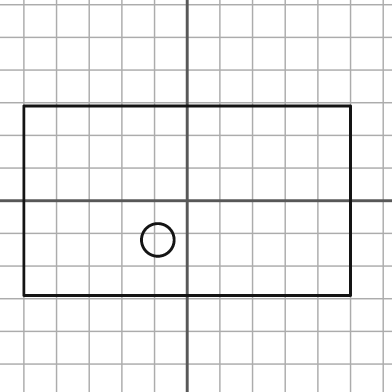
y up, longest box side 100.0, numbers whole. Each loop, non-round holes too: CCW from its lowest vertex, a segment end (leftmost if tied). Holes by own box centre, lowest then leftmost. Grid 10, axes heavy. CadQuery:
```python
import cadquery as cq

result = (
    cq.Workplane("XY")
    .moveTo(-50.0, -29.0)
    .lineTo(50.0, -29.0)
    .lineTo(50.0, 29.0)
    .lineTo(-50.0, 29.0)
    .close()
    .moveTo(-9.0, -12.0)
    .circle(5.0)
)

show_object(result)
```